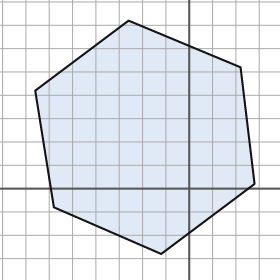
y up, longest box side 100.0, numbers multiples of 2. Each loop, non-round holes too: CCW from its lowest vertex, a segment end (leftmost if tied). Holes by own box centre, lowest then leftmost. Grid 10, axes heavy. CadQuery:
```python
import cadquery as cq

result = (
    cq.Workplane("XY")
    .moveTo(-12.0, -28.0)
    .lineTo(28.0, 2.0)
    .lineTo(22.0, 52.0)
    .lineTo(-26.0, 72.0)
    .lineTo(-66.0, 42.0)
    .lineTo(-58.0, -8.0)
    .close()
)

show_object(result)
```